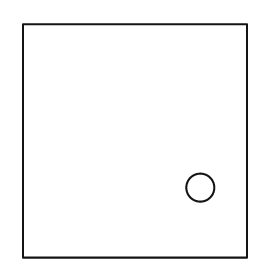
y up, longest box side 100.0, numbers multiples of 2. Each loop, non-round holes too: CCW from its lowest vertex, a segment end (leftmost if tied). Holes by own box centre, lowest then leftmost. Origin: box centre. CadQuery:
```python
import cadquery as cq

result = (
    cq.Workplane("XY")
    .moveTo(-48.0, -50.0)
    .lineTo(48.0, -50.0)
    .lineTo(48.0, 50.0)
    .lineTo(-48.0, 50.0)
    .close()
    .moveTo(28.0, -20.0)
    .circle(6.0)
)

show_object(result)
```